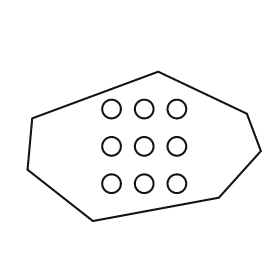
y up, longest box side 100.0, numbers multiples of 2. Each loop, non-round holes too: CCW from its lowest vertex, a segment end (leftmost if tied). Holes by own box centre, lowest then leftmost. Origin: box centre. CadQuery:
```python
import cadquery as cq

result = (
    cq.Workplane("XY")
    .moveTo(-22.0, -32.0)
    .lineTo(32.0, -22.0)
    .lineTo(50.0, -2.0)
    .lineTo(44.0, 14.0)
    .lineTo(6.0, 32.0)
    .lineTo(-48.0, 12.0)
    .lineTo(-50.0, -10.0)
    .close()
    .moveTo(-14.0, -16.0)
    .circle(4.0)
    .moveTo(0.0, -16.0)
    .circle(4.0)
    .moveTo(14.0, -16.0)
    .circle(4.0)
    .moveTo(-14.0, 0.0)
    .circle(4.0)
    .moveTo(0.0, 0.0)
    .circle(4.0)
    .moveTo(14.0, 0.0)
    .circle(4.0)
    .moveTo(-14.0, 16.0)
    .circle(4.0)
    .moveTo(0.0, 16.0)
    .circle(4.0)
    .moveTo(14.0, 16.0)
    .circle(4.0)
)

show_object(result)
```